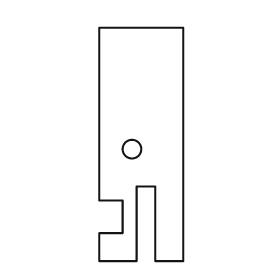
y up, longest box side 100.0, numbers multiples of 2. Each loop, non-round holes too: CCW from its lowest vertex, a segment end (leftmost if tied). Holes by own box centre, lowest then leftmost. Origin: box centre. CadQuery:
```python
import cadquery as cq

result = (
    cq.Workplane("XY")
    .moveTo(-18.0, -50.0)
    .lineTo(-2.0, -50.0)
    .lineTo(-2.0, -18.0)
    .lineTo(6.0, -18.0)
    .lineTo(6.0, -50.0)
    .lineTo(18.0, -50.0)
    .lineTo(18.0, 50.0)
    .lineTo(-18.0, 50.0)
    .lineTo(-18.0, -24.0)
    .lineTo(-8.0, -24.0)
    .lineTo(-8.0, -38.0)
    .lineTo(-18.0, -38.0)
    .close()
    .moveTo(-4.0, -2.0)
    .circle(4.0)
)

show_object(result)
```